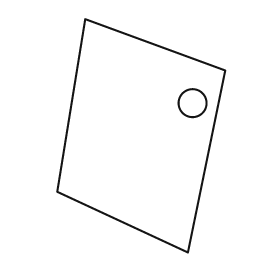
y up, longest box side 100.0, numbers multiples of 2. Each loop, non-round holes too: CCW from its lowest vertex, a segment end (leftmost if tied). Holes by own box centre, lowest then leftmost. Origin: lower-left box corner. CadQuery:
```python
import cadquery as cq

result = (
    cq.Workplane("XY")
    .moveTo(56.0, 0.0)
    .lineTo(72.0, 78.0)
    .lineTo(12.0, 100.0)
    .lineTo(0.0, 26.0)
    .close()
    .moveTo(58.0, 64.0)
    .circle(6.0)
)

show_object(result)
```